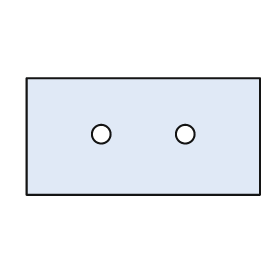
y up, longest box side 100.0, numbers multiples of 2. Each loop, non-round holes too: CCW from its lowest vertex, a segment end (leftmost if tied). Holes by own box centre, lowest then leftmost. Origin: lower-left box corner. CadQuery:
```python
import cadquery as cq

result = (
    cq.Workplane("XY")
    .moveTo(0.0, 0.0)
    .lineTo(100.0, 0.0)
    .lineTo(100.0, 50.0)
    .lineTo(0.0, 50.0)
    .close()
    .moveTo(32.0, 26.0)
    .circle(4.0)
    .moveTo(68.0, 26.0)
    .circle(4.0)
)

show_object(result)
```